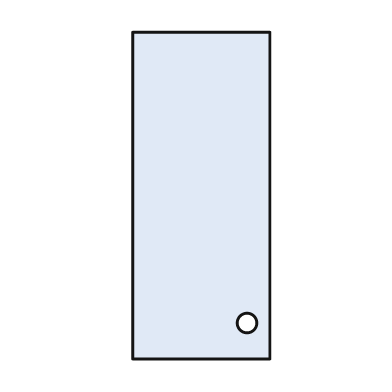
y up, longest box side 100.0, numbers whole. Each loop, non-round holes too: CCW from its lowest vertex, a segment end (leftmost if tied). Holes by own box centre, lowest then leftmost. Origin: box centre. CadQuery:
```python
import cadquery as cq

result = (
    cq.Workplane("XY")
    .moveTo(-21.0, -50.0)
    .lineTo(21.0, -50.0)
    .lineTo(21.0, 50.0)
    .lineTo(-21.0, 50.0)
    .close()
    .moveTo(14.0, -39.0)
    .circle(3.0)
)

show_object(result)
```